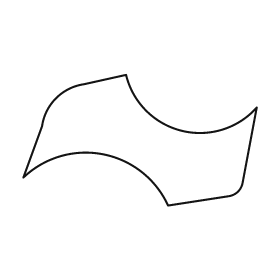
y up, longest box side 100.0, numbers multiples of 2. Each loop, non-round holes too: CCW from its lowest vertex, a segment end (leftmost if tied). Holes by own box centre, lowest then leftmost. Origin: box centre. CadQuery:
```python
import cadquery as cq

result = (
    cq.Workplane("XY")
    .moveTo(12.0, -28.0)
    .lineTo(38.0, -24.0)
    .threePointArc((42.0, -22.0), (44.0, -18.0))
    .lineTo(50.0, 14.0)
    .threePointArc((18.0, 4.0), (-6.0, 28.0))
    .lineTo(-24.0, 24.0)
    .threePointArc((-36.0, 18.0), (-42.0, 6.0))
    .lineTo(-50.0, -16.0)
    .threePointArc((-16.0, -6.0), (12.0, -28.0))
    .close()
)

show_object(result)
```